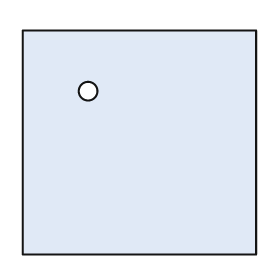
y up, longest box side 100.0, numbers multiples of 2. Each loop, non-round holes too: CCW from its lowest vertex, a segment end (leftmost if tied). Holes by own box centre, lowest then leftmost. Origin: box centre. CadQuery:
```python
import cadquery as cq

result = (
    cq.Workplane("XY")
    .moveTo(-50.0, -48.0)
    .lineTo(50.0, -48.0)
    .lineTo(50.0, 48.0)
    .lineTo(-50.0, 48.0)
    .close()
    .moveTo(-22.0, 22.0)
    .circle(4.0)
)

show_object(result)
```